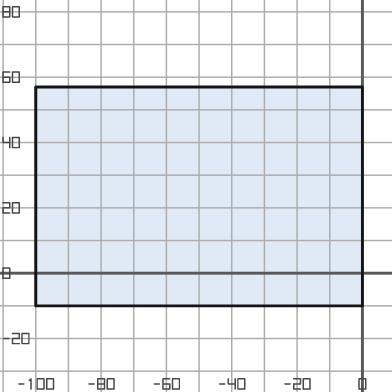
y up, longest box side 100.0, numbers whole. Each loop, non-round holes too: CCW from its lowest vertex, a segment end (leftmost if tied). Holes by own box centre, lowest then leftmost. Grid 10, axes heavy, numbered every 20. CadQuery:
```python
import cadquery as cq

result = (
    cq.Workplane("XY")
    .moveTo(-100.0, -10.0)
    .lineTo(0.0, -10.0)
    .lineTo(0.0, 57.0)
    .lineTo(-100.0, 57.0)
    .close()
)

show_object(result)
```